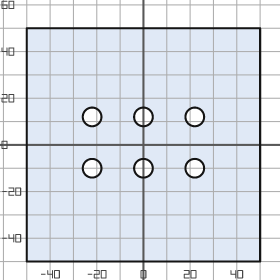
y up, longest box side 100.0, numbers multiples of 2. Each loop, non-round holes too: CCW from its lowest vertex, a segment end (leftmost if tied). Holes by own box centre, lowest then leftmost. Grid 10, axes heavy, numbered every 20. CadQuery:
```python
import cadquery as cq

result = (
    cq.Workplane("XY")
    .moveTo(-50.0, -50.0)
    .lineTo(50.0, -50.0)
    .lineTo(50.0, 50.0)
    .lineTo(-50.0, 50.0)
    .close()
    .moveTo(-22.0, -10.0)
    .circle(4.0)
    .moveTo(0.0, -10.0)
    .circle(4.0)
    .moveTo(22.0, -10.0)
    .circle(4.0)
    .moveTo(-22.0, 12.0)
    .circle(4.0)
    .moveTo(0.0, 12.0)
    .circle(4.0)
    .moveTo(22.0, 12.0)
    .circle(4.0)
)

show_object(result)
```